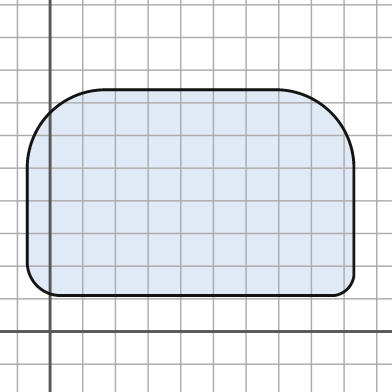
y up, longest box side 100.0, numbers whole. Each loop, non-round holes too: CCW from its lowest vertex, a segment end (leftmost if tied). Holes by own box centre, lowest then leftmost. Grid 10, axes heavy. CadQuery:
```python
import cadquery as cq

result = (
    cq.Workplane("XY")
    .moveTo(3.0, 11.0)
    .lineTo(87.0, 11.0)
    .threePointArc((91.0, 13.0), (93.0, 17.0))
    .lineTo(93.0, 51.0)
    .threePointArc((86.0, 67.0), (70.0, 74.0))
    .lineTo(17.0, 74.0)
    .threePointArc((0.0, 67.0), (-7.0, 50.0))
    .lineTo(-7.0, 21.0)
    .threePointArc((-4.0, 14.0), (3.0, 11.0))
    .close()
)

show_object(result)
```